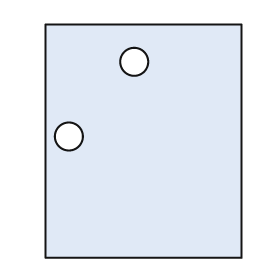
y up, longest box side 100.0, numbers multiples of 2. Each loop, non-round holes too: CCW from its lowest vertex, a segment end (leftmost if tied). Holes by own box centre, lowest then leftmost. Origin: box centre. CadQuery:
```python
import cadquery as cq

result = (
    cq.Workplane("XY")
    .moveTo(-42.0, -50.0)
    .lineTo(42.0, -50.0)
    .lineTo(42.0, 50.0)
    .lineTo(-42.0, 50.0)
    .close()
    .moveTo(-32.0, 2.0)
    .circle(6.0)
    .moveTo(-4.0, 34.0)
    .circle(6.0)
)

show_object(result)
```